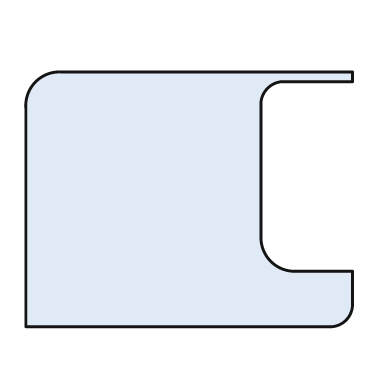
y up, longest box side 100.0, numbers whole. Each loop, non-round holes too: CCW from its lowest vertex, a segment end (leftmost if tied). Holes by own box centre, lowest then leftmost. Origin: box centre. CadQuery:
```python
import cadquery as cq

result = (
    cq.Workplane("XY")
    .moveTo(-50.0, -39.0)
    .lineTo(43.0, -39.0)
    .threePointArc((48.0, -37.0), (50.0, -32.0))
    .lineTo(50.0, -22.0)
    .lineTo(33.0, -22.0)
    .threePointArc((25.0, -19.0), (22.0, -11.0))
    .lineTo(22.0, 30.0)
    .threePointArc((24.0, 34.0), (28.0, 36.0))
    .lineTo(50.0, 36.0)
    .lineTo(50.0, 39.0)
    .lineTo(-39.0, 39.0)
    .threePointArc((-47.0, 36.0), (-50.0, 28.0))
    .close()
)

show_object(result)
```